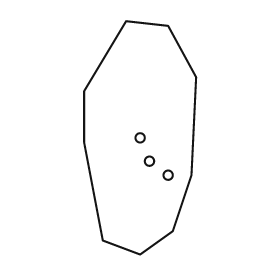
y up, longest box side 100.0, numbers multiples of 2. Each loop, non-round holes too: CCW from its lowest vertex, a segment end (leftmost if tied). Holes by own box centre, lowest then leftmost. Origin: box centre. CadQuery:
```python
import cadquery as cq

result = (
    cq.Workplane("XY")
    .moveTo(0.0, -50.0)
    .lineTo(14.0, -40.0)
    .lineTo(22.0, -16.0)
    .lineTo(24.0, 26.0)
    .lineTo(12.0, 48.0)
    .lineTo(-6.0, 50.0)
    .lineTo(-24.0, 20.0)
    .lineTo(-24.0, -2.0)
    .lineTo(-16.0, -44.0)
    .close()
    .moveTo(12.0, -16.0)
    .circle(2.0)
    .moveTo(4.0, -10.0)
    .circle(2.0)
    .moveTo(0.0, 0.0)
    .circle(2.0)
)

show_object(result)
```